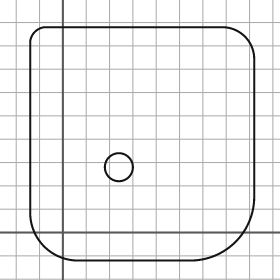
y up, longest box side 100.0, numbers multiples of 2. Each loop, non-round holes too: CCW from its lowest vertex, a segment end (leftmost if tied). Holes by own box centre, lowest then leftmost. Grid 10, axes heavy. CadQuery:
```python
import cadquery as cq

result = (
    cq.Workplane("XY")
    .moveTo(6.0, -12.0)
    .lineTo(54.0, -12.0)
    .threePointArc((74.0, -4.0), (82.0, 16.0))
    .lineTo(82.0, 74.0)
    .threePointArc((78.0, 84.0), (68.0, 88.0))
    .lineTo(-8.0, 88.0)
    .threePointArc((-12.0, 86.0), (-14.0, 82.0))
    .lineTo(-14.0, 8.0)
    .threePointArc((-8.0, -6.0), (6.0, -12.0))
    .close()
    .moveTo(24.0, 28.0)
    .circle(6.0)
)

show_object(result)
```